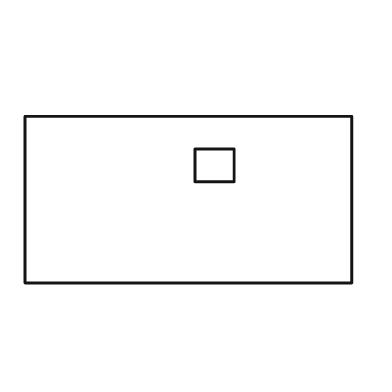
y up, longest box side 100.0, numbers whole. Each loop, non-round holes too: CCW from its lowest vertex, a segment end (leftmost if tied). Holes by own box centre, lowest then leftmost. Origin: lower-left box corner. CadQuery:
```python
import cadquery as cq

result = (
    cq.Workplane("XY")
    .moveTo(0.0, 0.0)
    .lineTo(100.0, 0.0)
    .lineTo(100.0, 51.0)
    .lineTo(0.0, 51.0)
    .close()
    .moveTo(52.0, 31.0)
    .lineTo(64.0, 31.0)
    .lineTo(64.0, 41.0)
    .lineTo(52.0, 41.0)
    .close()
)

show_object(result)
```